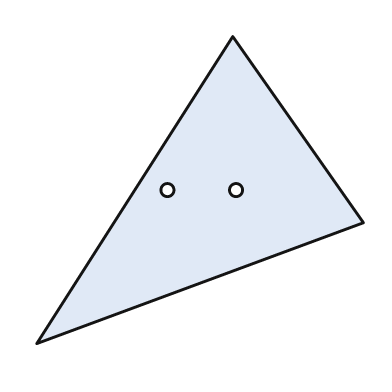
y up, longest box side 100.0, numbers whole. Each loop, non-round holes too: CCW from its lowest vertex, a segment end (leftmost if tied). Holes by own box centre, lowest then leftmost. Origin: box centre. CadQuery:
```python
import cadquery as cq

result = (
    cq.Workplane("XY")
    .moveTo(-50.0, -47.0)
    .lineTo(50.0, -10.0)
    .lineTo(10.0, 47.0)
    .close()
    .moveTo(-10.0, 0.0)
    .circle(2.0)
    .moveTo(11.0, 0.0)
    .circle(2.0)
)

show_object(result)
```